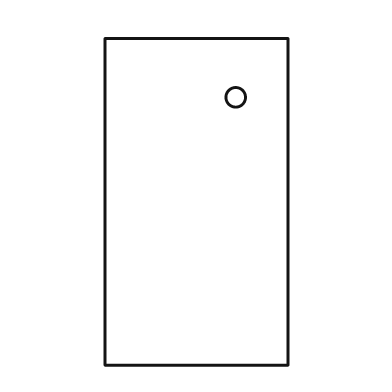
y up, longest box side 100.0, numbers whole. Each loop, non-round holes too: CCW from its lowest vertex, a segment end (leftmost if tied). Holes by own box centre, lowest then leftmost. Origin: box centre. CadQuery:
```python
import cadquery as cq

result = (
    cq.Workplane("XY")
    .moveTo(-28.0, -50.0)
    .lineTo(28.0, -50.0)
    .lineTo(28.0, 50.0)
    .lineTo(-28.0, 50.0)
    .close()
    .moveTo(12.0, 32.0)
    .circle(3.0)
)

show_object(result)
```